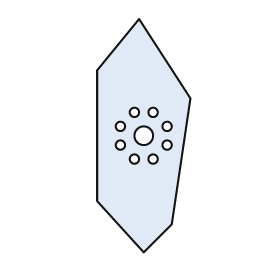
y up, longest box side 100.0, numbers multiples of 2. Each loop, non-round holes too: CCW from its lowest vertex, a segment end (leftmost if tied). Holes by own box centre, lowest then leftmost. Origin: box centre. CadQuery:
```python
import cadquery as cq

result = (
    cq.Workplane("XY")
    .moveTo(0.0, -50.0)
    .lineTo(12.0, -38.0)
    .lineTo(20.0, 16.0)
    .lineTo(-2.0, 50.0)
    .lineTo(-20.0, 28.0)
    .lineTo(-20.0, -28.0)
    .close()
    .moveTo(-4.0, -10.0)
    .circle(2.0)
    .moveTo(4.0, -10.0)
    .circle(2.0)
    .moveTo(-10.0, -4.0)
    .circle(2.0)
    .moveTo(10.0, -4.0)
    .circle(2.0)
    .moveTo(0.0, 0.0)
    .circle(4.0)
    .moveTo(-10.0, 4.0)
    .circle(2.0)
    .moveTo(10.0, 4.0)
    .circle(2.0)
    .moveTo(-4.0, 10.0)
    .circle(2.0)
    .moveTo(4.0, 10.0)
    .circle(2.0)
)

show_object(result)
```